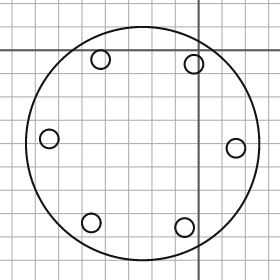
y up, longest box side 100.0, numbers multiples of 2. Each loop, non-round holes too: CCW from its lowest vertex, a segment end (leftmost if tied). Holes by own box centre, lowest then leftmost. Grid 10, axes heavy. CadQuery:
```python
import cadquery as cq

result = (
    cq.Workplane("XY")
    .moveTo(-24.0, -40.0)
    .circle(50.0)
    .moveTo(-6.0, -76.0)
    .circle(4.0)
    .moveTo(-46.0, -74.0)
    .circle(4.0)
    .moveTo(16.0, -42.0)
    .circle(4.0)
    .moveTo(-64.0, -38.0)
    .circle(4.0)
    .moveTo(-2.0, -6.0)
    .circle(4.0)
    .moveTo(-42.0, -4.0)
    .circle(4.0)
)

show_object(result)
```